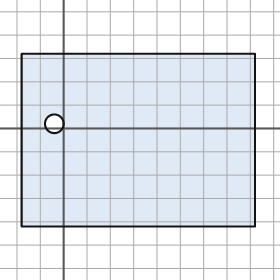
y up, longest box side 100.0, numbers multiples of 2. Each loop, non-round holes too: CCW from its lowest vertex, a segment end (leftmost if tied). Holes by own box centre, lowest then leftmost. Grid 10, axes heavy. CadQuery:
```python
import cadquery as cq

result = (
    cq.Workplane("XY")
    .moveTo(-18.0, -42.0)
    .lineTo(82.0, -42.0)
    .lineTo(82.0, 32.0)
    .lineTo(-18.0, 32.0)
    .close()
    .moveTo(-4.0, 2.0)
    .circle(4.0)
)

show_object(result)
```